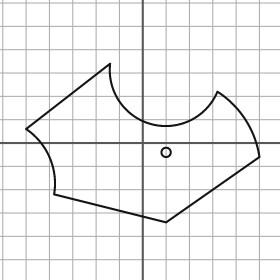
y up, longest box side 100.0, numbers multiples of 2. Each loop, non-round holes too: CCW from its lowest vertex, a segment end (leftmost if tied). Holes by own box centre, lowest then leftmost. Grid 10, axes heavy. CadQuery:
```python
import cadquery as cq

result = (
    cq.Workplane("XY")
    .moveTo(10.0, -34.0)
    .lineTo(50.0, -6.0)
    .threePointArc((44.0, 10.0), (32.0, 22.0))
    .threePointArc((4.0, 8.0), (-14.0, 34.0))
    .lineTo(-50.0, 6.0)
    .threePointArc((-40.0, -6.0), (-38.0, -22.0))
    .close()
    .moveTo(10.0, -4.0)
    .circle(2.0)
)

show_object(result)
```